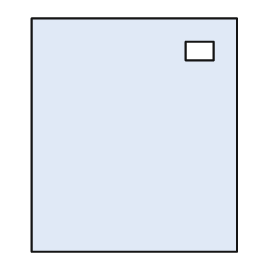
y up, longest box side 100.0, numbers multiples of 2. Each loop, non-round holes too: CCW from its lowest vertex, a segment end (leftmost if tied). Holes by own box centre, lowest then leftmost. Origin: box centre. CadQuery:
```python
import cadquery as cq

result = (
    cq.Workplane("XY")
    .moveTo(-44.0, -50.0)
    .lineTo(44.0, -50.0)
    .lineTo(44.0, 50.0)
    .lineTo(-44.0, 50.0)
    .close()
    .moveTo(22.0, 32.0)
    .lineTo(34.0, 32.0)
    .lineTo(34.0, 40.0)
    .lineTo(22.0, 40.0)
    .close()
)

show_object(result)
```